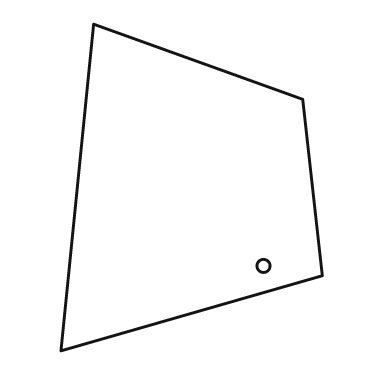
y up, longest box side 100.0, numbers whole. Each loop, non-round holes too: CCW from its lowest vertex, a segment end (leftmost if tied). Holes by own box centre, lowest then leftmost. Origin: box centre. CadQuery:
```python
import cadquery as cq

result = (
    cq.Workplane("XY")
    .moveTo(-40.0, -50.0)
    .lineTo(40.0, -27.0)
    .lineTo(34.0, 27.0)
    .lineTo(-30.0, 50.0)
    .close()
    .moveTo(22.0, -24.0)
    .circle(2.0)
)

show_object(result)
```